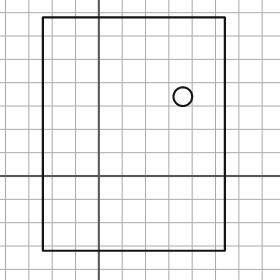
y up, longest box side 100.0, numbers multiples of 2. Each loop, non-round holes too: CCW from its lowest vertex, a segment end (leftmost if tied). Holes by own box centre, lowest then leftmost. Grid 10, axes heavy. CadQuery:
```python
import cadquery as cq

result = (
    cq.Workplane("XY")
    .moveTo(-24.0, -32.0)
    .lineTo(54.0, -32.0)
    .lineTo(54.0, 68.0)
    .lineTo(-24.0, 68.0)
    .close()
    .moveTo(36.0, 34.0)
    .circle(4.0)
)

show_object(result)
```